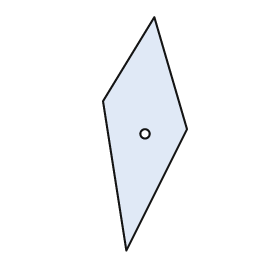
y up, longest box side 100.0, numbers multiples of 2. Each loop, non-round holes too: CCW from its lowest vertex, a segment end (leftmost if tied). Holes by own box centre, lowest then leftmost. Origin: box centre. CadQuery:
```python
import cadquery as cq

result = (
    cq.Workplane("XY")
    .moveTo(-8.0, -50.0)
    .lineTo(18.0, 2.0)
    .lineTo(4.0, 50.0)
    .lineTo(-18.0, 14.0)
    .close()
    .moveTo(0.0, 0.0)
    .circle(2.0)
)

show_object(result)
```